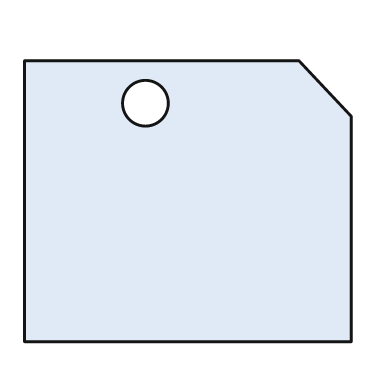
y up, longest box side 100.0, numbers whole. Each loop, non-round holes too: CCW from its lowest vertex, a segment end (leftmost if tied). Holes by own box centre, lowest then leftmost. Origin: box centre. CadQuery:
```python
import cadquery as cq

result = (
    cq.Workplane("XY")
    .moveTo(-50.0, -43.0)
    .lineTo(50.0, -43.0)
    .lineTo(50.0, 26.0)
    .lineTo(34.0, 43.0)
    .lineTo(-50.0, 43.0)
    .close()
    .moveTo(-13.0, 30.0)
    .circle(7.0)
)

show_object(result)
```